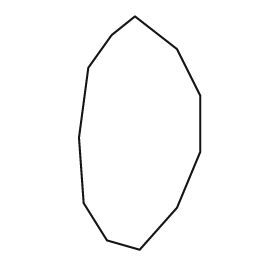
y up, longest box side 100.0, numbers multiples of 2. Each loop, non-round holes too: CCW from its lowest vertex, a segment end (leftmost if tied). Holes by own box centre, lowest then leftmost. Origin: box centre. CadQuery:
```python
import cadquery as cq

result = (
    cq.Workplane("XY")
    .moveTo(0.0, -50.0)
    .lineTo(16.0, -32.0)
    .lineTo(26.0, -8.0)
    .lineTo(26.0, 16.0)
    .lineTo(16.0, 36.0)
    .lineTo(-2.0, 50.0)
    .lineTo(-12.0, 42.0)
    .lineTo(-22.0, 28.0)
    .lineTo(-26.0, -2.0)
    .lineTo(-24.0, -30.0)
    .lineTo(-14.0, -46.0)
    .close()
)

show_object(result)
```